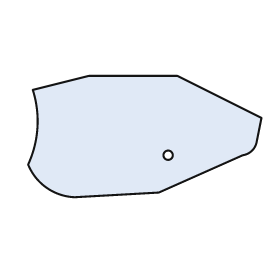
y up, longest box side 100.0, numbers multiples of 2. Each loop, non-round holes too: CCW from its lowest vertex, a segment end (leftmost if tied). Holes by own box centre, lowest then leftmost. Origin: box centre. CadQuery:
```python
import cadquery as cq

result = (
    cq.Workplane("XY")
    .moveTo(-30.0, -26.0)
    .lineTo(6.0, -24.0)
    .lineTo(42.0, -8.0)
    .threePointArc((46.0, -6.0), (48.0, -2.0))
    .lineTo(50.0, 8.0)
    .lineTo(14.0, 26.0)
    .lineTo(-24.0, 26.0)
    .lineTo(-48.0, 20.0)
    .threePointArc((-46.0, 4.0), (-50.0, -12.0))
    .threePointArc((-42.0, -22.0), (-30.0, -26.0))
    .close()
    .moveTo(10.0, -8.0)
    .circle(2.0)
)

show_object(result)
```